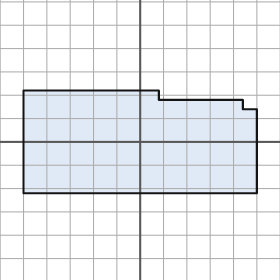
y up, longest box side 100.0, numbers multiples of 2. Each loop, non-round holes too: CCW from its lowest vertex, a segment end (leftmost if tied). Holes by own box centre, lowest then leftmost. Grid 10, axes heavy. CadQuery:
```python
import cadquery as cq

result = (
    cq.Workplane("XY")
    .moveTo(-50.0, -22.0)
    .lineTo(50.0, -22.0)
    .lineTo(50.0, 14.0)
    .lineTo(44.0, 14.0)
    .lineTo(44.0, 18.0)
    .lineTo(8.0, 18.0)
    .lineTo(8.0, 22.0)
    .lineTo(-50.0, 22.0)
    .close()
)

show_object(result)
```